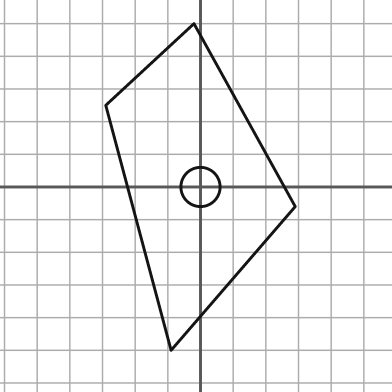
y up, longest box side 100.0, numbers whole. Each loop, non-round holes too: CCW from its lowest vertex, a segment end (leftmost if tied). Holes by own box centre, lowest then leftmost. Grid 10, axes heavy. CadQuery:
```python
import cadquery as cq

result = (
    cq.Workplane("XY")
    .moveTo(-9.0, -50.0)
    .lineTo(29.0, -6.0)
    .lineTo(-2.0, 50.0)
    .lineTo(-29.0, 25.0)
    .close()
    .moveTo(0.0, 0.0)
    .circle(6.0)
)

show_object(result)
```